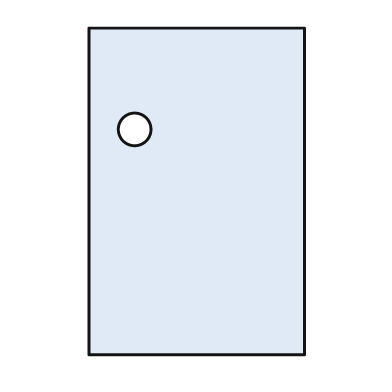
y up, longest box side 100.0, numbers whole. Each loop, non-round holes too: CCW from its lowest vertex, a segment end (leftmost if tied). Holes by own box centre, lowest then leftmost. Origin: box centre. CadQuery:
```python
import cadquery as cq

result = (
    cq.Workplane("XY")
    .moveTo(-33.0, -50.0)
    .lineTo(33.0, -50.0)
    .lineTo(33.0, 50.0)
    .lineTo(-33.0, 50.0)
    .close()
    .moveTo(-19.0, 19.0)
    .circle(5.0)
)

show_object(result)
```